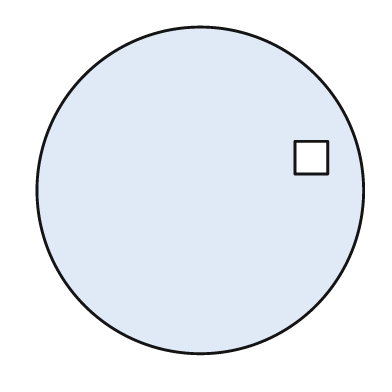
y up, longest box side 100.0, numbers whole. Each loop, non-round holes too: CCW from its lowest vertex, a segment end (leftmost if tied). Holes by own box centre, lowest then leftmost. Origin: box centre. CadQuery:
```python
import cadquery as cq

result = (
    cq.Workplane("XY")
    .moveTo(0.0, 0.0)
    .circle(50.0)
    .moveTo(29.0, 5.0)
    .lineTo(39.0, 5.0)
    .lineTo(39.0, 15.0)
    .lineTo(29.0, 15.0)
    .close()
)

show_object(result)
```